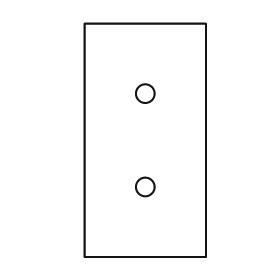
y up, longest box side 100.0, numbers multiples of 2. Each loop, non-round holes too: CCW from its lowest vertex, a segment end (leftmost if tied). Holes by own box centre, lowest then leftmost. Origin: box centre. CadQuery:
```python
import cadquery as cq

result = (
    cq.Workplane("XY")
    .moveTo(-26.0, -50.0)
    .lineTo(26.0, -50.0)
    .lineTo(26.0, 50.0)
    .lineTo(-26.0, 50.0)
    .close()
    .moveTo(0.0, -20.0)
    .circle(4.0)
    .moveTo(0.0, 20.0)
    .circle(4.0)
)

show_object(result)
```